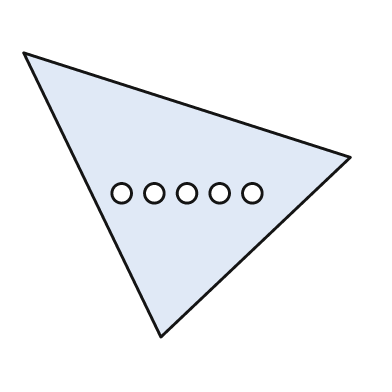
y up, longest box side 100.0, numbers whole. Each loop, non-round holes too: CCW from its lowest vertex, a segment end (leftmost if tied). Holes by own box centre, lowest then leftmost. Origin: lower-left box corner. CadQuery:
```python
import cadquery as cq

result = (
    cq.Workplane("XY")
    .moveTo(42.0, 0.0)
    .lineTo(100.0, 55.0)
    .lineTo(0.0, 87.0)
    .close()
    .moveTo(30.0, 44.0)
    .circle(3.0)
    .moveTo(40.0, 44.0)
    .circle(3.0)
    .moveTo(50.0, 44.0)
    .circle(3.0)
    .moveTo(60.0, 44.0)
    .circle(3.0)
    .moveTo(70.0, 44.0)
    .circle(3.0)
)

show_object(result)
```